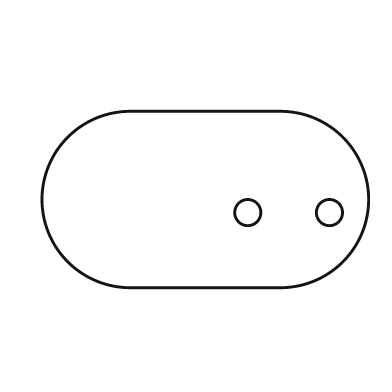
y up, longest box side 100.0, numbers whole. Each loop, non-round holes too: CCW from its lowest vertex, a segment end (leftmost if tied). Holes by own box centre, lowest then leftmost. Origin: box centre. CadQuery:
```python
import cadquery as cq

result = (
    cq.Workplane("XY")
    .moveTo(-23.0, -27.0)
    .lineTo(23.0, -27.0)
    .threePointArc((50.0, 0.0), (23.0, 27.0))
    .lineTo(-23.0, 27.0)
    .threePointArc((-50.0, 0.0), (-23.0, -27.0))
    .close()
    .moveTo(13.0, -4.0)
    .circle(4.0)
    .moveTo(38.0, -4.0)
    .circle(4.0)
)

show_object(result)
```